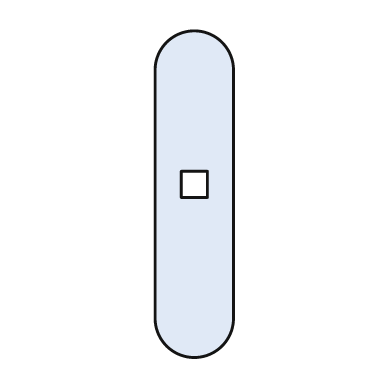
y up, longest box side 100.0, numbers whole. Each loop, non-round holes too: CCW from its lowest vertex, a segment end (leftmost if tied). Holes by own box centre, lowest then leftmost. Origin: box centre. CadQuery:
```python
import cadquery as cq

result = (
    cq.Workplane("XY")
    .moveTo(-12.0, -38.0)
    .threePointArc((0.0, -50.0), (12.0, -38.0))
    .lineTo(12.0, 38.0)
    .threePointArc((0.0, 50.0), (-12.0, 38.0))
    .close()
    .moveTo(-4.0, -1.0)
    .lineTo(4.0, -1.0)
    .lineTo(4.0, 7.0)
    .lineTo(-4.0, 7.0)
    .close()
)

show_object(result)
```